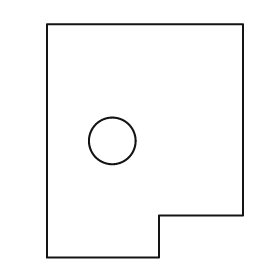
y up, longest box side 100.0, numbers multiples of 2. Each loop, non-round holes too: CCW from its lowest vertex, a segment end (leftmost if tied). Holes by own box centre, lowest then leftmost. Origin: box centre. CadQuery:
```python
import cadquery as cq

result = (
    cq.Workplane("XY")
    .moveTo(-42.0, -50.0)
    .lineTo(6.0, -50.0)
    .lineTo(6.0, -32.0)
    .lineTo(42.0, -32.0)
    .lineTo(42.0, 50.0)
    .lineTo(-42.0, 50.0)
    .close()
    .moveTo(-14.0, 0.0)
    .circle(10.0)
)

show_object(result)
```